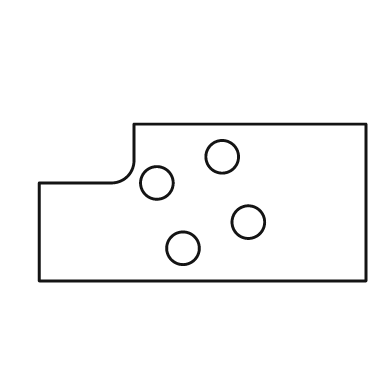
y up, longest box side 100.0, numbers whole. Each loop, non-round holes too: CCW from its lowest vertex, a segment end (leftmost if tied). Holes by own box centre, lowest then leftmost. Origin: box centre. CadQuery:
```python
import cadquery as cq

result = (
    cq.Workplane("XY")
    .moveTo(-50.0, -24.0)
    .lineTo(50.0, -24.0)
    .lineTo(50.0, 24.0)
    .lineTo(-21.0, 24.0)
    .lineTo(-21.0, 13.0)
    .threePointArc((-23.0, 8.0), (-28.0, 6.0))
    .lineTo(-50.0, 6.0)
    .close()
    .moveTo(-6.0, -14.0)
    .circle(5.0)
    .moveTo(14.0, -6.0)
    .circle(5.0)
    .moveTo(-14.0, 6.0)
    .circle(5.0)
    .moveTo(6.0, 14.0)
    .circle(5.0)
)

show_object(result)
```